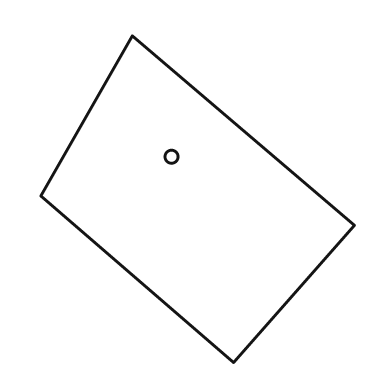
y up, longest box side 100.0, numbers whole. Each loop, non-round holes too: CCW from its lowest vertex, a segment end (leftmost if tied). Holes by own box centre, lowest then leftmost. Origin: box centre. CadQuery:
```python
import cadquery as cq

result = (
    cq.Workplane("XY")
    .moveTo(11.0, -50.0)
    .lineTo(48.0, -8.0)
    .lineTo(-20.0, 50.0)
    .lineTo(-48.0, 1.0)
    .close()
    .moveTo(-8.0, 13.0)
    .circle(2.0)
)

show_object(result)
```